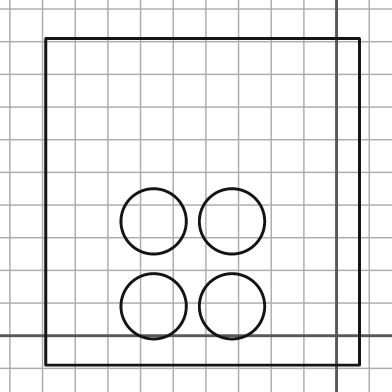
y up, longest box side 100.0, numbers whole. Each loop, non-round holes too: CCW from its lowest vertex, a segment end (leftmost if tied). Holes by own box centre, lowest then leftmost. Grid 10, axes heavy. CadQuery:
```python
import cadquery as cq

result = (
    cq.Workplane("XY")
    .moveTo(-89.0, -9.0)
    .lineTo(7.0, -9.0)
    .lineTo(7.0, 91.0)
    .lineTo(-89.0, 91.0)
    .close()
    .moveTo(-56.0, 9.0)
    .circle(10.0)
    .moveTo(-32.0, 9.0)
    .circle(10.0)
    .moveTo(-56.0, 35.0)
    .circle(10.0)
    .moveTo(-32.0, 35.0)
    .circle(10.0)
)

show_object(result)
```